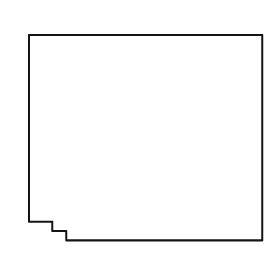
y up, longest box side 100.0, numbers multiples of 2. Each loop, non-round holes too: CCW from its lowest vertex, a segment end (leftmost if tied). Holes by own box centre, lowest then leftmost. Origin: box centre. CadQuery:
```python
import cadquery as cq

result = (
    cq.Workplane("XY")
    .moveTo(-34.0, -44.0)
    .lineTo(50.0, -44.0)
    .lineTo(50.0, 44.0)
    .lineTo(-50.0, 44.0)
    .lineTo(-50.0, -36.0)
    .lineTo(-40.0, -36.0)
    .lineTo(-40.0, -40.0)
    .lineTo(-34.0, -40.0)
    .close()
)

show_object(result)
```